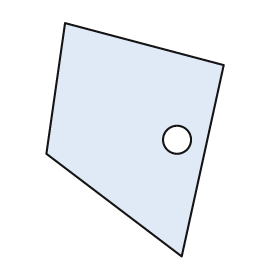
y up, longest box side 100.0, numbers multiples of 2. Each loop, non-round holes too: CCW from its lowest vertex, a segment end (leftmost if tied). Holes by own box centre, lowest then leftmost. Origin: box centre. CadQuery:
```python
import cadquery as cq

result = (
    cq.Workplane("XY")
    .moveTo(20.0, -50.0)
    .lineTo(38.0, 32.0)
    .lineTo(-30.0, 50.0)
    .lineTo(-38.0, -6.0)
    .close()
    .moveTo(18.0, 0.0)
    .circle(6.0)
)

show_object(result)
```